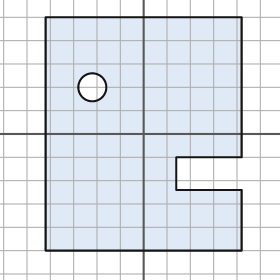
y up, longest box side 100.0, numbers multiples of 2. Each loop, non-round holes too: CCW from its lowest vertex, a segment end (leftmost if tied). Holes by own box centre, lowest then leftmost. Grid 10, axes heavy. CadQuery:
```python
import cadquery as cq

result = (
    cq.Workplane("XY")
    .moveTo(-42.0, -50.0)
    .lineTo(42.0, -50.0)
    .lineTo(42.0, -24.0)
    .lineTo(14.0, -24.0)
    .lineTo(14.0, -10.0)
    .lineTo(42.0, -10.0)
    .lineTo(42.0, 50.0)
    .lineTo(-42.0, 50.0)
    .close()
    .moveTo(-22.0, 20.0)
    .circle(6.0)
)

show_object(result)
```